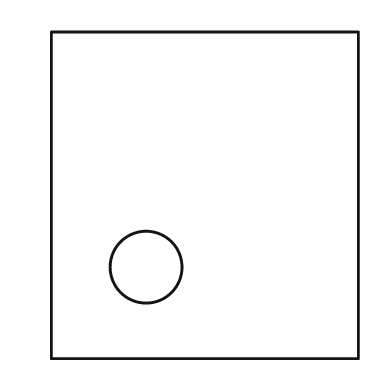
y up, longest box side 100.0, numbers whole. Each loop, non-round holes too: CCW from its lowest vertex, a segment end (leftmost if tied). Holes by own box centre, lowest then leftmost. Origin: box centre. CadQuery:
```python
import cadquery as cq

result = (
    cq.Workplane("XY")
    .moveTo(-47.0, -50.0)
    .lineTo(47.0, -50.0)
    .lineTo(47.0, 50.0)
    .lineTo(-47.0, 50.0)
    .close()
    .moveTo(-18.0, -22.0)
    .circle(11.0)
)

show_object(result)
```